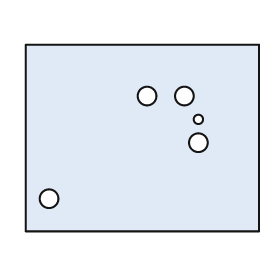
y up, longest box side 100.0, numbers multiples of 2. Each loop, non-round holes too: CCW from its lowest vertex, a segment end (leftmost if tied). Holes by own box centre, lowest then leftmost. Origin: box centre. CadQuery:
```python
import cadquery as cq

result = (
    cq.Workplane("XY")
    .moveTo(-50.0, -40.0)
    .lineTo(50.0, -40.0)
    .lineTo(50.0, 40.0)
    .lineTo(-50.0, 40.0)
    .close()
    .moveTo(-40.0, -26.0)
    .circle(4.0)
    .moveTo(24.0, -2.0)
    .circle(4.0)
    .moveTo(24.0, 8.0)
    .circle(2.0)
    .moveTo(2.0, 18.0)
    .circle(4.0)
    .moveTo(18.0, 18.0)
    .circle(4.0)
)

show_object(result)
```